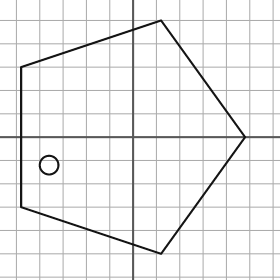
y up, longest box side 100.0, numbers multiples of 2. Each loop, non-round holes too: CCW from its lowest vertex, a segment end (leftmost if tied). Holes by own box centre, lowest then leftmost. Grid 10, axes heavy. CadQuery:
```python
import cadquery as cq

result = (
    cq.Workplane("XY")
    .moveTo(12.0, -50.0)
    .lineTo(48.0, 0.0)
    .lineTo(12.0, 50.0)
    .lineTo(-48.0, 30.0)
    .lineTo(-48.0, -30.0)
    .close()
    .moveTo(-36.0, -12.0)
    .circle(4.0)
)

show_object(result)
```